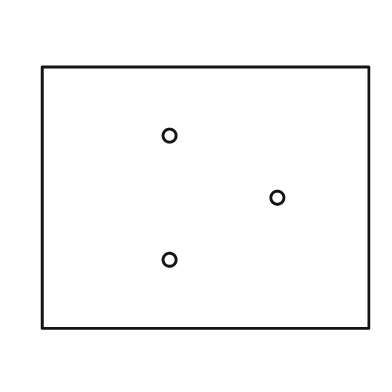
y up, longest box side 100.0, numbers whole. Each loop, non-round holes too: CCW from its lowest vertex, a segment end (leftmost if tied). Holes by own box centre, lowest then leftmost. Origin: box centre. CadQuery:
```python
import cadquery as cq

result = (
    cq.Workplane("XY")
    .moveTo(-50.0, -40.0)
    .lineTo(50.0, -40.0)
    .lineTo(50.0, 40.0)
    .lineTo(-50.0, 40.0)
    .close()
    .moveTo(-11.0, -19.0)
    .circle(2.0)
    .moveTo(22.0, 0.0)
    .circle(2.0)
    .moveTo(-11.0, 19.0)
    .circle(2.0)
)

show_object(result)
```